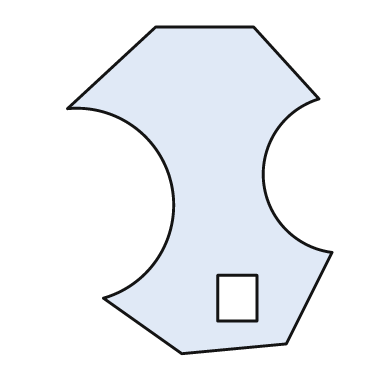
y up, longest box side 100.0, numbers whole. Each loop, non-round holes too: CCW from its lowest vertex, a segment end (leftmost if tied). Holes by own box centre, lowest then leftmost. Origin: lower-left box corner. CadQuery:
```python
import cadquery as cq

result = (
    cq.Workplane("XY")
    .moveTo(35.0, 0.0)
    .lineTo(67.0, 3.0)
    .lineTo(81.0, 31.0)
    .threePointArc((60.0, 53.0), (77.0, 78.0))
    .lineTo(57.0, 100.0)
    .lineTo(27.0, 100.0)
    .lineTo(0.0, 75.0)
    .threePointArc((32.0, 51.0), (11.0, 17.0))
    .close()
    .moveTo(46.0, 10.0)
    .lineTo(58.0, 10.0)
    .lineTo(58.0, 24.0)
    .lineTo(46.0, 24.0)
    .close()
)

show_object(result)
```